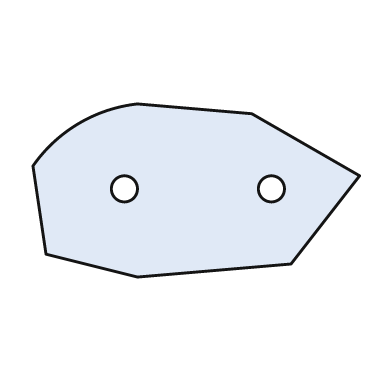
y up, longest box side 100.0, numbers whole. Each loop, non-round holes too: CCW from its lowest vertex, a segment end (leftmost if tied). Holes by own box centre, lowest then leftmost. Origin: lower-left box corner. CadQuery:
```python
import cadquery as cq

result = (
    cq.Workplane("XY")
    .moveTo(32.0, 0.0)
    .lineTo(79.0, 4.0)
    .lineTo(100.0, 31.0)
    .lineTo(67.0, 50.0)
    .lineTo(32.0, 53.0)
    .threePointArc((14.0, 47.0), (0.0, 34.0))
    .lineTo(4.0, 7.0)
    .close()
    .moveTo(28.0, 27.0)
    .circle(4.0)
    .moveTo(73.0, 27.0)
    .circle(4.0)
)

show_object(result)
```